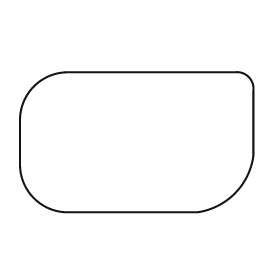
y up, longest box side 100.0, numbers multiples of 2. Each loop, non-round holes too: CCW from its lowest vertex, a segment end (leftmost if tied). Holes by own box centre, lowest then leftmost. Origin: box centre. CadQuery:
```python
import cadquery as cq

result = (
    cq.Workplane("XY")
    .moveTo(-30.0, -30.0)
    .lineTo(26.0, -30.0)
    .threePointArc((42.0, -22.0), (50.0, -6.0))
    .lineTo(50.0, 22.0)
    .threePointArc((48.0, 28.0), (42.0, 30.0))
    .lineTo(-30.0, 30.0)
    .threePointArc((-44.0, 24.0), (-50.0, 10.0))
    .lineTo(-50.0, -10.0)
    .threePointArc((-44.0, -24.0), (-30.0, -30.0))
    .close()
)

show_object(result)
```